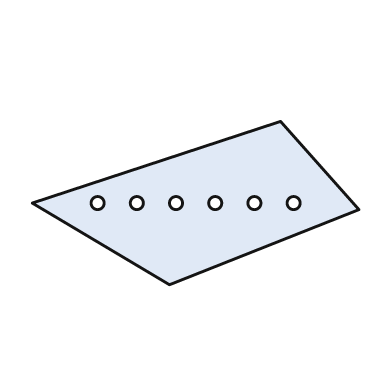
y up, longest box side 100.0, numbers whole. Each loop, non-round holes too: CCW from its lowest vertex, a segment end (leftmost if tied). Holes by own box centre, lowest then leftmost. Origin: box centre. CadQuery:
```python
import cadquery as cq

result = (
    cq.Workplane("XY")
    .moveTo(-8.0, -25.0)
    .lineTo(50.0, -2.0)
    .lineTo(26.0, 25.0)
    .lineTo(-50.0, 0.0)
    .close()
    .moveTo(-30.0, 0.0)
    .circle(2.0)
    .moveTo(-18.0, 0.0)
    .circle(2.0)
    .moveTo(-6.0, 0.0)
    .circle(2.0)
    .moveTo(6.0, 0.0)
    .circle(2.0)
    .moveTo(18.0, 0.0)
    .circle(2.0)
    .moveTo(30.0, 0.0)
    .circle(2.0)
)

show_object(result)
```